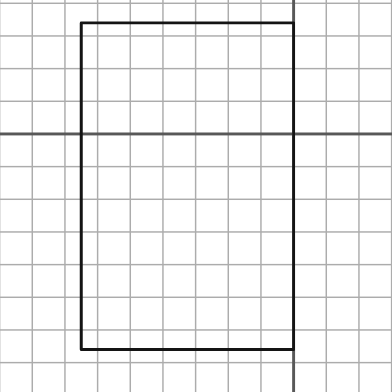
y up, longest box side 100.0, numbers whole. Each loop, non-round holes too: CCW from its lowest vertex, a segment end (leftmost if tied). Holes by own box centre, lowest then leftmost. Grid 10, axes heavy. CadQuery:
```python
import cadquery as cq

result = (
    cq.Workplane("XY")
    .moveTo(-65.0, -66.0)
    .lineTo(0.0, -66.0)
    .lineTo(0.0, 34.0)
    .lineTo(-65.0, 34.0)
    .close()
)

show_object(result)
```